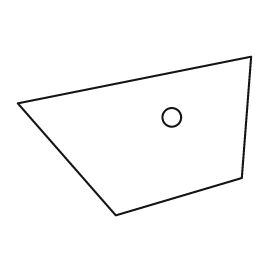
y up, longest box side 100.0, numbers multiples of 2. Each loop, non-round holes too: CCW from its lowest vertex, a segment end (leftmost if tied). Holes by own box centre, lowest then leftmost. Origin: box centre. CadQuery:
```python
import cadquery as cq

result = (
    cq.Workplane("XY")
    .moveTo(-8.0, -34.0)
    .lineTo(46.0, -18.0)
    .lineTo(50.0, 34.0)
    .lineTo(-50.0, 14.0)
    .close()
    .moveTo(16.0, 8.0)
    .circle(4.0)
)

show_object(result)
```